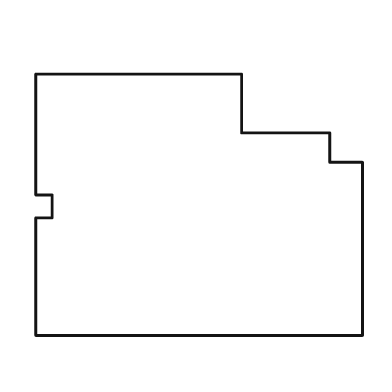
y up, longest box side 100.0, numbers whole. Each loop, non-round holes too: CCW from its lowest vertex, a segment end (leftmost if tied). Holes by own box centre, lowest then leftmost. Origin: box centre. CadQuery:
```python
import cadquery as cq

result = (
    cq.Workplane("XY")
    .moveTo(-50.0, -40.0)
    .lineTo(50.0, -40.0)
    .lineTo(50.0, 13.0)
    .lineTo(40.0, 13.0)
    .lineTo(40.0, 22.0)
    .lineTo(13.0, 22.0)
    .lineTo(13.0, 40.0)
    .lineTo(-50.0, 40.0)
    .lineTo(-50.0, 3.0)
    .lineTo(-45.0, 3.0)
    .lineTo(-45.0, -4.0)
    .lineTo(-50.0, -4.0)
    .close()
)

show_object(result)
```